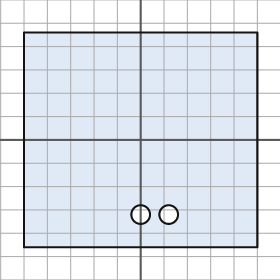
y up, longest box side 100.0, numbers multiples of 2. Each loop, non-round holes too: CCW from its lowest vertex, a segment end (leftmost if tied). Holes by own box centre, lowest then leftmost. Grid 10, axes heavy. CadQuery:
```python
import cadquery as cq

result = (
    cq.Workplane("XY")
    .moveTo(-50.0, -46.0)
    .lineTo(50.0, -46.0)
    .lineTo(50.0, 46.0)
    .lineTo(-50.0, 46.0)
    .close()
    .moveTo(0.0, -32.0)
    .circle(4.0)
    .moveTo(12.0, -32.0)
    .circle(4.0)
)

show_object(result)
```